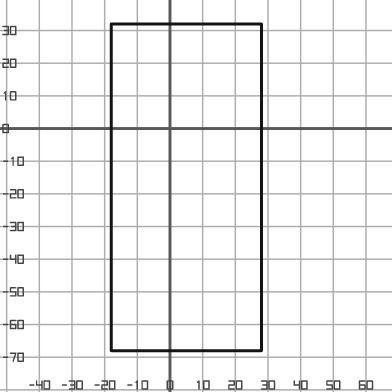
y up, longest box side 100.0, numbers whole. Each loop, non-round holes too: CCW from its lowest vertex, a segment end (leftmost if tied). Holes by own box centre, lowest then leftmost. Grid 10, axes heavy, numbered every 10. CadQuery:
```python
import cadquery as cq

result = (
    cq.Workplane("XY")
    .moveTo(-18.0, -68.0)
    .lineTo(28.0, -68.0)
    .lineTo(28.0, 32.0)
    .lineTo(-18.0, 32.0)
    .close()
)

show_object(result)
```